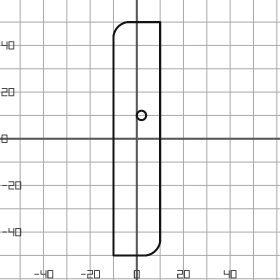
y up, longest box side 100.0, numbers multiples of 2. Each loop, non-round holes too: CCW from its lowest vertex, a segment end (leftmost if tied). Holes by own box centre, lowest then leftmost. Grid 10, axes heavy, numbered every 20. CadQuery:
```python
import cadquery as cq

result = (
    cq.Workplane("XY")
    .moveTo(-10.0, -50.0)
    .lineTo(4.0, -50.0)
    .threePointArc((8.0, -48.0), (10.0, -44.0))
    .lineTo(10.0, 50.0)
    .lineTo(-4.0, 50.0)
    .threePointArc((-8.0, 48.0), (-10.0, 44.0))
    .close()
    .moveTo(2.0, 10.0)
    .circle(2.0)
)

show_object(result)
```